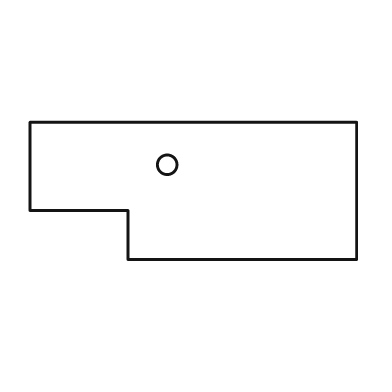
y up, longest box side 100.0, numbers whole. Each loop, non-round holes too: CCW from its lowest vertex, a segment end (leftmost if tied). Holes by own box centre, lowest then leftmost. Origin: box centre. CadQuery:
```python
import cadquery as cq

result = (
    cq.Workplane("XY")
    .moveTo(-20.0, -21.0)
    .lineTo(50.0, -21.0)
    .lineTo(50.0, 21.0)
    .lineTo(-50.0, 21.0)
    .lineTo(-50.0, -6.0)
    .lineTo(-20.0, -6.0)
    .close()
    .moveTo(-8.0, 8.0)
    .circle(3.0)
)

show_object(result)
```